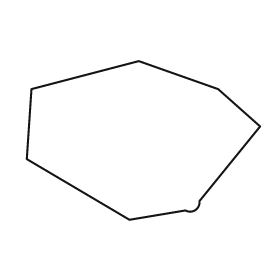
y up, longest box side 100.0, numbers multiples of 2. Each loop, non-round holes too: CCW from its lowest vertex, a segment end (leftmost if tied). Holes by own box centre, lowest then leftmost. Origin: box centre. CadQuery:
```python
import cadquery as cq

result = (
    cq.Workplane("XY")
    .moveTo(-6.0, -34.0)
    .lineTo(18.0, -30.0)
    .threePointArc((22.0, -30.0), (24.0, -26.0))
    .lineTo(50.0, 6.0)
    .lineTo(32.0, 22.0)
    .lineTo(-2.0, 34.0)
    .lineTo(-48.0, 22.0)
    .lineTo(-50.0, -8.0)
    .close()
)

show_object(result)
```